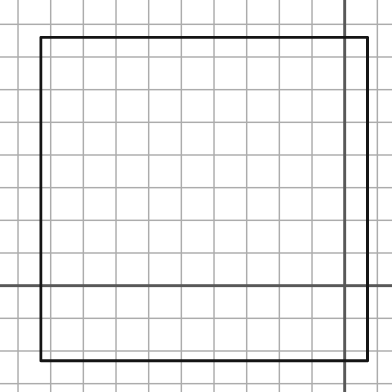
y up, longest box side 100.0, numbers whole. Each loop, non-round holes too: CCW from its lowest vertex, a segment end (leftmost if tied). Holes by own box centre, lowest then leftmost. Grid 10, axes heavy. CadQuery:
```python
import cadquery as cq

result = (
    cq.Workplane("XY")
    .moveTo(-93.0, -23.0)
    .lineTo(7.0, -23.0)
    .lineTo(7.0, 76.0)
    .lineTo(-93.0, 76.0)
    .close()
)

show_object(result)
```